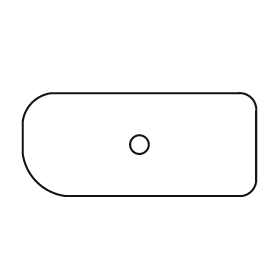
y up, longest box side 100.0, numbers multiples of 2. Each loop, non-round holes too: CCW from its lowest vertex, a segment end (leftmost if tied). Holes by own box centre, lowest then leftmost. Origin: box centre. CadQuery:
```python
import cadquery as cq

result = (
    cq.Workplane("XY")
    .moveTo(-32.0, -22.0)
    .lineTo(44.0, -22.0)
    .threePointArc((48.0, -20.0), (50.0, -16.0))
    .lineTo(50.0, 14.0)
    .threePointArc((48.0, 20.0), (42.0, 22.0))
    .lineTo(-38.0, 22.0)
    .threePointArc((-46.0, 18.0), (-50.0, 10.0))
    .lineTo(-50.0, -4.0)
    .threePointArc((-44.0, -16.0), (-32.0, -22.0))
    .close()
    .moveTo(0.0, 0.0)
    .circle(4.0)
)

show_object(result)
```